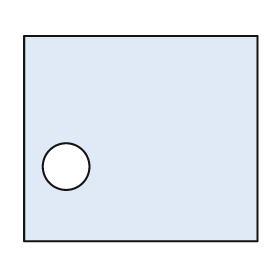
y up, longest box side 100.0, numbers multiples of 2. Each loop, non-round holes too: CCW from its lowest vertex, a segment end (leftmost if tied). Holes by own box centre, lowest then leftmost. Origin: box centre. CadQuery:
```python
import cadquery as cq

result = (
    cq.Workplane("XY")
    .moveTo(-50.0, -44.0)
    .lineTo(50.0, -44.0)
    .lineTo(50.0, 44.0)
    .lineTo(-50.0, 44.0)
    .close()
    .moveTo(-32.0, -12.0)
    .circle(10.0)
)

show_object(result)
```